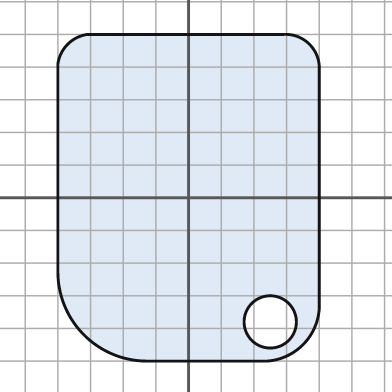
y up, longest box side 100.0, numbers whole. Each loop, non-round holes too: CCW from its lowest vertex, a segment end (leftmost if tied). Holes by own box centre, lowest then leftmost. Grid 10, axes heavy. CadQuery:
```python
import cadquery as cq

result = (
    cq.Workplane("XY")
    .moveTo(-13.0, -50.0)
    .lineTo(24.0, -50.0)
    .threePointArc((35.0, -45.0), (40.0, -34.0))
    .lineTo(40.0, 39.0)
    .threePointArc((37.0, 47.0), (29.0, 50.0))
    .lineTo(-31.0, 50.0)
    .threePointArc((-37.0, 47.0), (-40.0, 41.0))
    .lineTo(-40.0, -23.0)
    .threePointArc((-32.0, -42.0), (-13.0, -50.0))
    .close()
    .moveTo(25.0, -38.0)
    .circle(8.0)
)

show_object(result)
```